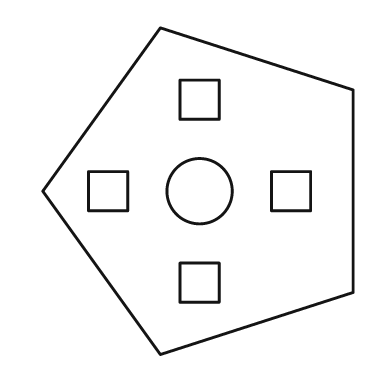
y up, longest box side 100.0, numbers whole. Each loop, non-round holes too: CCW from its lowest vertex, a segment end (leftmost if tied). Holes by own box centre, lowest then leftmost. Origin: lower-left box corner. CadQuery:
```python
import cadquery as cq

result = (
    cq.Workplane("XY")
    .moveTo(36.0, 0.0)
    .lineTo(95.0, 19.0)
    .lineTo(95.0, 81.0)
    .lineTo(36.0, 100.0)
    .lineTo(0.0, 50.0)
    .close()
    .moveTo(42.0, 16.0)
    .lineTo(54.0, 16.0)
    .lineTo(54.0, 28.0)
    .lineTo(42.0, 28.0)
    .close()
    .moveTo(14.0, 44.0)
    .lineTo(26.0, 44.0)
    .lineTo(26.0, 56.0)
    .lineTo(14.0, 56.0)
    .close()
    .moveTo(48.0, 50.0)
    .circle(10.0)
    .moveTo(70.0, 44.0)
    .lineTo(82.0, 44.0)
    .lineTo(82.0, 56.0)
    .lineTo(70.0, 56.0)
    .close()
    .moveTo(42.0, 72.0)
    .lineTo(54.0, 72.0)
    .lineTo(54.0, 84.0)
    .lineTo(42.0, 84.0)
    .close()
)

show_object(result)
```